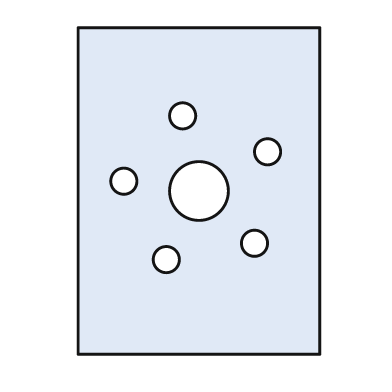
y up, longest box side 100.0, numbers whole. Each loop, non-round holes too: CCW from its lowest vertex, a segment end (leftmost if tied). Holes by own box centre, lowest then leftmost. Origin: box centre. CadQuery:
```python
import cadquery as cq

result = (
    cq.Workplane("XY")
    .moveTo(-37.0, -50.0)
    .lineTo(37.0, -50.0)
    .lineTo(37.0, 50.0)
    .lineTo(-37.0, 50.0)
    .close()
    .moveTo(-10.0, -21.0)
    .circle(4.0)
    .moveTo(17.0, -16.0)
    .circle(4.0)
    .moveTo(0.0, 0.0)
    .circle(9.0)
    .moveTo(-23.0, 3.0)
    .circle(4.0)
    .moveTo(21.0, 12.0)
    .circle(4.0)
    .moveTo(-5.0, 23.0)
    .circle(4.0)
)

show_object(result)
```